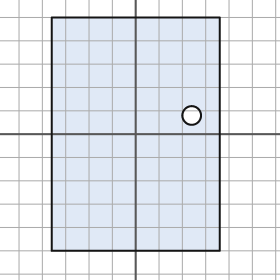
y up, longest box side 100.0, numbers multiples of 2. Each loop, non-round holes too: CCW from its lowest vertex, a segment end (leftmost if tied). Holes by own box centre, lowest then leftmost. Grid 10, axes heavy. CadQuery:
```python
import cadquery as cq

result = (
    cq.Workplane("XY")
    .moveTo(-36.0, -50.0)
    .lineTo(36.0, -50.0)
    .lineTo(36.0, 50.0)
    .lineTo(-36.0, 50.0)
    .close()
    .moveTo(24.0, 8.0)
    .circle(4.0)
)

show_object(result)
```